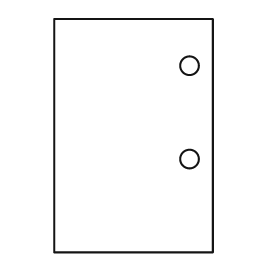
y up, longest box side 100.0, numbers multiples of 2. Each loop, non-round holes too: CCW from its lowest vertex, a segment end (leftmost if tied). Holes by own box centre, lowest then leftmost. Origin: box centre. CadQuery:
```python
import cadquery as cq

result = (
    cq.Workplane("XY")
    .moveTo(-34.0, -50.0)
    .lineTo(34.0, -50.0)
    .lineTo(34.0, 50.0)
    .lineTo(-34.0, 50.0)
    .close()
    .moveTo(24.0, -10.0)
    .circle(4.0)
    .moveTo(24.0, 30.0)
    .circle(4.0)
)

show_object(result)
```